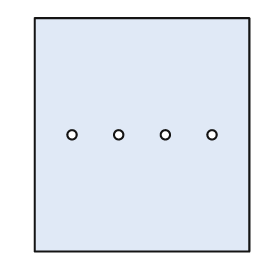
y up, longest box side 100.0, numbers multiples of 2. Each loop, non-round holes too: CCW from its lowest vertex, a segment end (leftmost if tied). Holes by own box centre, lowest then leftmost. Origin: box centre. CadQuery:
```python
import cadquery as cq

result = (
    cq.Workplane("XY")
    .moveTo(-46.0, -50.0)
    .lineTo(46.0, -50.0)
    .lineTo(46.0, 50.0)
    .lineTo(-46.0, 50.0)
    .close()
    .moveTo(-30.0, 0.0)
    .circle(2.0)
    .moveTo(-10.0, 0.0)
    .circle(2.0)
    .moveTo(10.0, 0.0)
    .circle(2.0)
    .moveTo(30.0, 0.0)
    .circle(2.0)
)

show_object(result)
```